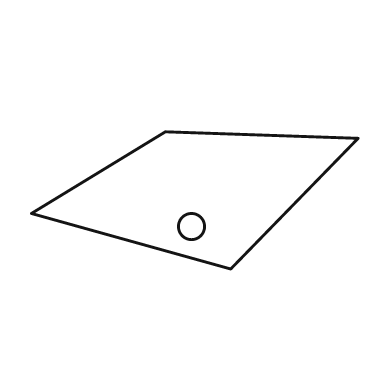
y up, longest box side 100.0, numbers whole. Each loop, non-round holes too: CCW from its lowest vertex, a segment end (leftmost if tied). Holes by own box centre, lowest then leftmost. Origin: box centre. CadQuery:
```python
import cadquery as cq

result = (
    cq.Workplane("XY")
    .moveTo(11.0, -21.0)
    .lineTo(50.0, 19.0)
    .lineTo(-9.0, 21.0)
    .lineTo(-50.0, -4.0)
    .close()
    .moveTo(-1.0, -8.0)
    .circle(4.0)
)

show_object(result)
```